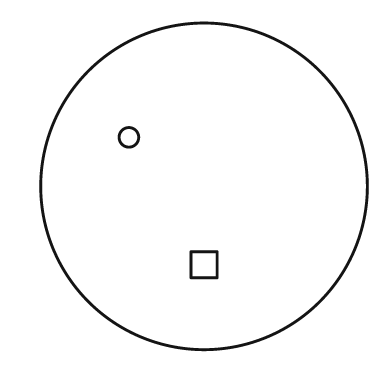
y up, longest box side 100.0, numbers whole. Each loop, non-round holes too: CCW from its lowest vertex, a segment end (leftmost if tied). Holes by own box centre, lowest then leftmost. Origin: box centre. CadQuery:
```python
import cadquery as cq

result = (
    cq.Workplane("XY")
    .moveTo(0.0, 0.0)
    .circle(50.0)
    .moveTo(-4.0, -28.0)
    .lineTo(4.0, -28.0)
    .lineTo(4.0, -20.0)
    .lineTo(-4.0, -20.0)
    .close()
    .moveTo(-23.0, 15.0)
    .circle(3.0)
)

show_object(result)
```